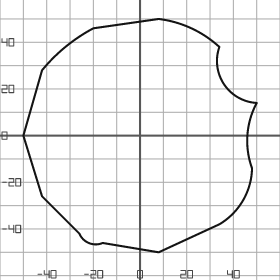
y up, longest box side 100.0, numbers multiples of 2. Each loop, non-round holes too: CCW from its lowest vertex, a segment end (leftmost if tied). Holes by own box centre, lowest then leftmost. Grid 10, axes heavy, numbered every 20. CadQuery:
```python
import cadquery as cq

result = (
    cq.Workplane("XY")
    .moveTo(8.0, -50.0)
    .lineTo(34.0, -38.0)
    .threePointArc((44.0, -28.0), (48.0, -14.0))
    .threePointArc((46.0, 0.0), (50.0, 14.0))
    .threePointArc((36.0, 22.0), (34.0, 38.0))
    .threePointArc((22.0, 46.0), (8.0, 50.0))
    .lineTo(-20.0, 46.0)
    .threePointArc((-32.0, 38.0), (-42.0, 28.0))
    .lineTo(-50.0, 0.0)
    .lineTo(-42.0, -26.0)
    .lineTo(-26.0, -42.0)
    .threePointArc((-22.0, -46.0), (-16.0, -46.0))
    .close()
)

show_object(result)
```